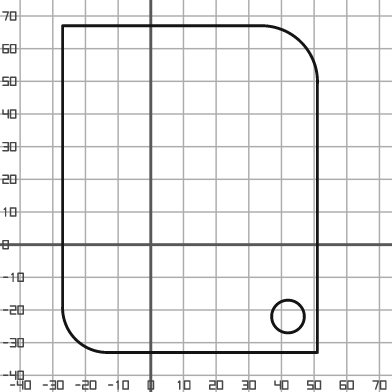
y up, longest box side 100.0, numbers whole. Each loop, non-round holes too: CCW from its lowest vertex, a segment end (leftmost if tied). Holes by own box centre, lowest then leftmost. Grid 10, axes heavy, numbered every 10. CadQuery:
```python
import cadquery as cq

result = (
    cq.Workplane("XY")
    .moveTo(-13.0, -33.0)
    .lineTo(51.0, -33.0)
    .lineTo(51.0, 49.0)
    .threePointArc((46.0, 62.0), (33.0, 67.0))
    .lineTo(-27.0, 67.0)
    .lineTo(-27.0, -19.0)
    .threePointArc((-23.0, -29.0), (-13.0, -33.0))
    .close()
    .moveTo(42.0, -22.0)
    .circle(5.0)
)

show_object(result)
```